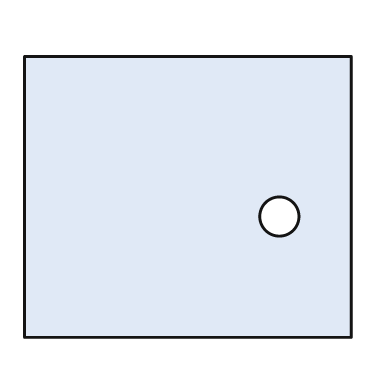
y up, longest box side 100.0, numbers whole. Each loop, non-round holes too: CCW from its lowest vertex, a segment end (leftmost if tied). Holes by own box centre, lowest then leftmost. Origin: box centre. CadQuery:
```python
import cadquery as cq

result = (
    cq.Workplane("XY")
    .moveTo(-50.0, -43.0)
    .lineTo(50.0, -43.0)
    .lineTo(50.0, 43.0)
    .lineTo(-50.0, 43.0)
    .close()
    .moveTo(28.0, -6.0)
    .circle(6.0)
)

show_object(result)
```